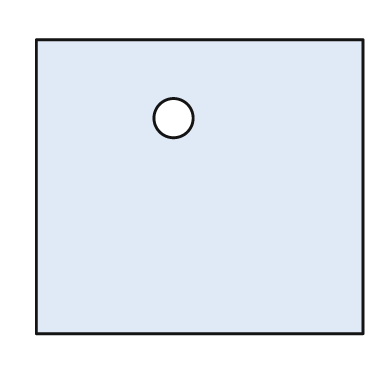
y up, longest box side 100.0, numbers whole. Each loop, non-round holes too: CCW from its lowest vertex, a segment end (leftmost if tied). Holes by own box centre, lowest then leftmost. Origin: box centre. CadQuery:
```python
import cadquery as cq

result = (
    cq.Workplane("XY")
    .moveTo(-50.0, -45.0)
    .lineTo(50.0, -45.0)
    .lineTo(50.0, 45.0)
    .lineTo(-50.0, 45.0)
    .close()
    .moveTo(-8.0, 21.0)
    .circle(6.0)
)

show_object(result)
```